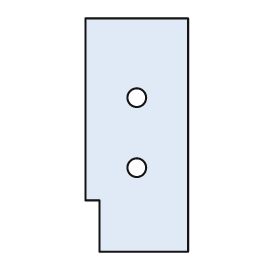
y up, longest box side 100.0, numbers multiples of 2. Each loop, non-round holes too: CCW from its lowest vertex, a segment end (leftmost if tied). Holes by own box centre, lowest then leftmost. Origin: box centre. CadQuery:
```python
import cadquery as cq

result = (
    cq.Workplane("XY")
    .moveTo(-16.0, -50.0)
    .lineTo(22.0, -50.0)
    .lineTo(22.0, 50.0)
    .lineTo(-22.0, 50.0)
    .lineTo(-22.0, -28.0)
    .lineTo(-16.0, -28.0)
    .close()
    .moveTo(0.0, -14.0)
    .circle(4.0)
    .moveTo(0.0, 16.0)
    .circle(4.0)
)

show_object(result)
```